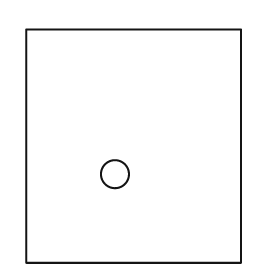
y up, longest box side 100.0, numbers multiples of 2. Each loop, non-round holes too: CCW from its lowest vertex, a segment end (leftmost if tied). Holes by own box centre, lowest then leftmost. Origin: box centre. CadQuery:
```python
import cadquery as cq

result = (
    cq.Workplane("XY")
    .moveTo(-46.0, -50.0)
    .lineTo(46.0, -50.0)
    .lineTo(46.0, 50.0)
    .lineTo(-46.0, 50.0)
    .close()
    .moveTo(-8.0, -12.0)
    .circle(6.0)
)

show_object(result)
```